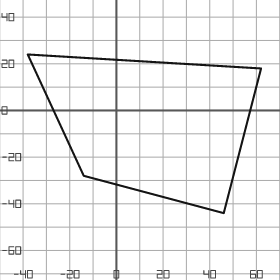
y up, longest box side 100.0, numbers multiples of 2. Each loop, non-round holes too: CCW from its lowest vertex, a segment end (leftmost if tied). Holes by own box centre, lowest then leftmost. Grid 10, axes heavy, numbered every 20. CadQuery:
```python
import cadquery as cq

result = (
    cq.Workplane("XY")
    .moveTo(46.0, -44.0)
    .lineTo(62.0, 18.0)
    .lineTo(-38.0, 24.0)
    .lineTo(-14.0, -28.0)
    .close()
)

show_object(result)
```